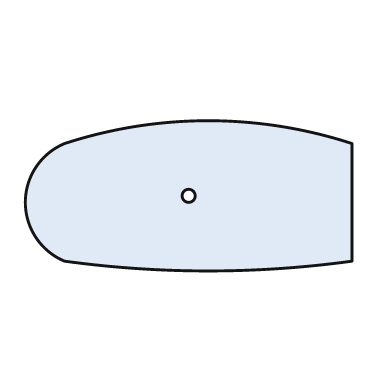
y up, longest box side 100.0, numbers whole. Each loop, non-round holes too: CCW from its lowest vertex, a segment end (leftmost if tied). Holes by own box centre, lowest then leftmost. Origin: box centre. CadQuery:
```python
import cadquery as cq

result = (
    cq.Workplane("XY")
    .moveTo(-38.0, -20.0)
    .threePointArc((6.0, -23.0), (50.0, -20.0))
    .lineTo(50.0, 16.0)
    .threePointArc((6.0, 23.0), (-38.0, 16.0))
    .threePointArc((-50.0, -2.0), (-38.0, -20.0))
    .close()
    .moveTo(0.0, 0.0)
    .circle(2.0)
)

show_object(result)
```